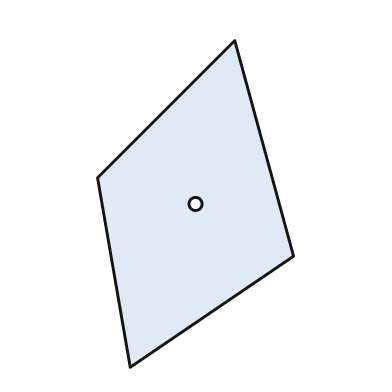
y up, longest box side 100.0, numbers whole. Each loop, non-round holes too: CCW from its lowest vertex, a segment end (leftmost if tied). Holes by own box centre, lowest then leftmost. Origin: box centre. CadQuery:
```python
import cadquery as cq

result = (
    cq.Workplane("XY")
    .moveTo(-20.0, -50.0)
    .lineTo(30.0, -16.0)
    .lineTo(12.0, 50.0)
    .lineTo(-30.0, 8.0)
    .close()
    .moveTo(0.0, 0.0)
    .circle(2.0)
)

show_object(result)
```